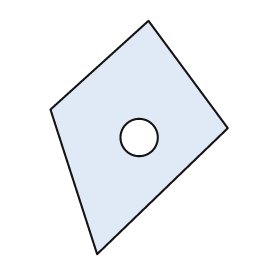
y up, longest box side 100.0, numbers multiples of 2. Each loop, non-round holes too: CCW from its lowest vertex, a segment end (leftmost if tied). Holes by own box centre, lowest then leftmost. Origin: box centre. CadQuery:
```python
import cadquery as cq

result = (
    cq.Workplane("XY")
    .moveTo(-18.0, -50.0)
    .lineTo(38.0, 4.0)
    .lineTo(4.0, 50.0)
    .lineTo(-38.0, 12.0)
    .close()
    .moveTo(0.0, 0.0)
    .circle(8.0)
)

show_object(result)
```